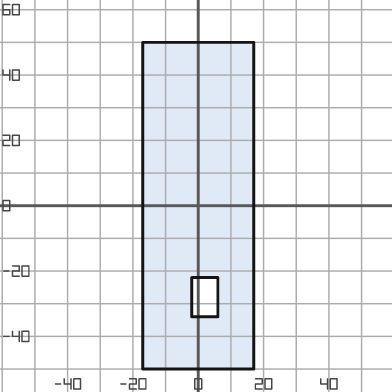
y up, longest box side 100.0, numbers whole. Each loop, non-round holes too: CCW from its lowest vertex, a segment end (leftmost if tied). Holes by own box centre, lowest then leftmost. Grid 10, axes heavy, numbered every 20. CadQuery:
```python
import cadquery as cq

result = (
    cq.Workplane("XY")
    .moveTo(-17.0, -50.0)
    .lineTo(17.0, -50.0)
    .lineTo(17.0, 50.0)
    .lineTo(-17.0, 50.0)
    .close()
    .moveTo(-2.0, -34.0)
    .lineTo(6.0, -34.0)
    .lineTo(6.0, -22.0)
    .lineTo(-2.0, -22.0)
    .close()
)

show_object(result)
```